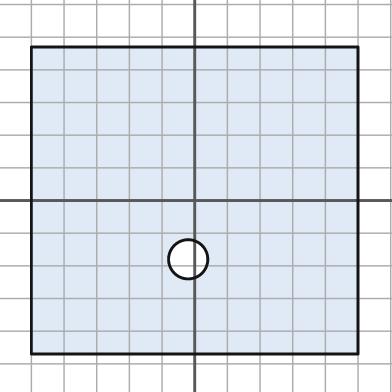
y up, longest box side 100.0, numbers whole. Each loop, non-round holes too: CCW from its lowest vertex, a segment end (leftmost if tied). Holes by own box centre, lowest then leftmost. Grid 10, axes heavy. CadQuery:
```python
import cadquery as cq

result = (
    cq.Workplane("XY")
    .moveTo(-50.0, -47.0)
    .lineTo(50.0, -47.0)
    .lineTo(50.0, 47.0)
    .lineTo(-50.0, 47.0)
    .close()
    .moveTo(-2.0, -18.0)
    .circle(6.0)
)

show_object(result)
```